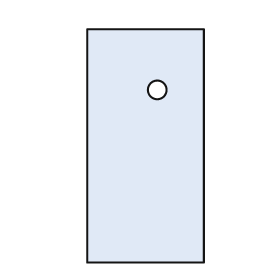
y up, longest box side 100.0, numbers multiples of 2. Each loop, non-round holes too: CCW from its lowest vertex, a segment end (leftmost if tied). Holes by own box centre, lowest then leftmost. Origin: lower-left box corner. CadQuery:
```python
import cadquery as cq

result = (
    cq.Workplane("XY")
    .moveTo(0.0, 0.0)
    .lineTo(50.0, 0.0)
    .lineTo(50.0, 100.0)
    .lineTo(0.0, 100.0)
    .close()
    .moveTo(30.0, 74.0)
    .circle(4.0)
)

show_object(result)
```